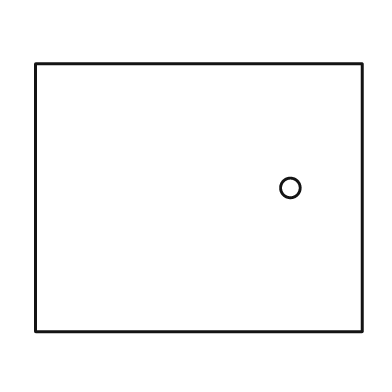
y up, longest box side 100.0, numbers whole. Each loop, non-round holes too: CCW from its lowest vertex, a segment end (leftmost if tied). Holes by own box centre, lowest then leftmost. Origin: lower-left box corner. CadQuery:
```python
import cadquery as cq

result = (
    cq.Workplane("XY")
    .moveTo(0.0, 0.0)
    .lineTo(100.0, 0.0)
    .lineTo(100.0, 82.0)
    .lineTo(0.0, 82.0)
    .close()
    .moveTo(78.0, 44.0)
    .circle(3.0)
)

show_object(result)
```